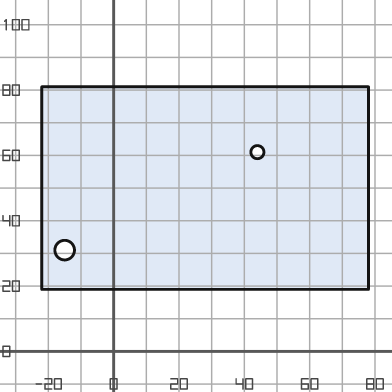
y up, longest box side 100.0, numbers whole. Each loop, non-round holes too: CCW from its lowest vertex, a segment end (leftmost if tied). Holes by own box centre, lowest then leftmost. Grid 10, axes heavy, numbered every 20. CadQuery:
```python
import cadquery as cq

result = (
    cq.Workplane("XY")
    .moveTo(-22.0, 19.0)
    .lineTo(78.0, 19.0)
    .lineTo(78.0, 81.0)
    .lineTo(-22.0, 81.0)
    .close()
    .moveTo(-15.0, 31.0)
    .circle(3.0)
    .moveTo(44.0, 61.0)
    .circle(2.0)
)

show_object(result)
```